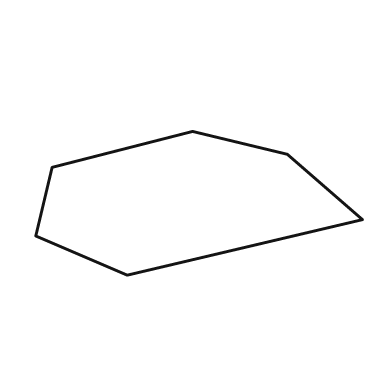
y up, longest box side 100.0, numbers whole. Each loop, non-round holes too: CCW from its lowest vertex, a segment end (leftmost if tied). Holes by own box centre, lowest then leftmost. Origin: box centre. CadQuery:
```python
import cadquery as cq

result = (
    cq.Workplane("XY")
    .moveTo(-22.0, -22.0)
    .lineTo(50.0, -5.0)
    .lineTo(27.0, 15.0)
    .lineTo(-2.0, 22.0)
    .lineTo(-45.0, 11.0)
    .lineTo(-50.0, -10.0)
    .close()
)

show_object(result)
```